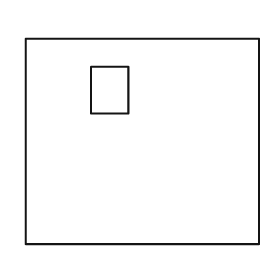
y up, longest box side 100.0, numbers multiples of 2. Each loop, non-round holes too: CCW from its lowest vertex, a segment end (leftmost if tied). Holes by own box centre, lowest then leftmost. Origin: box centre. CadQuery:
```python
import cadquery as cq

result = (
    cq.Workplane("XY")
    .moveTo(-50.0, -44.0)
    .lineTo(50.0, -44.0)
    .lineTo(50.0, 44.0)
    .lineTo(-50.0, 44.0)
    .close()
    .moveTo(-22.0, 12.0)
    .lineTo(-6.0, 12.0)
    .lineTo(-6.0, 32.0)
    .lineTo(-22.0, 32.0)
    .close()
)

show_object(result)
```